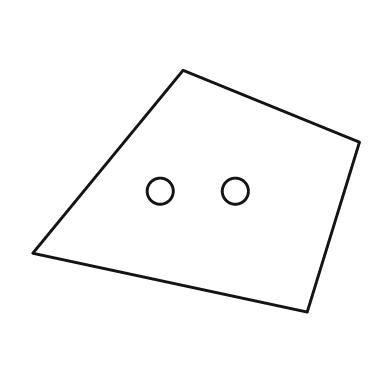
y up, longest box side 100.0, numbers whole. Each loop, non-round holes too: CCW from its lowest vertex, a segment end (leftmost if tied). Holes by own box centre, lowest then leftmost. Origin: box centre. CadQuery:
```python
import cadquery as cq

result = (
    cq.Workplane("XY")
    .moveTo(34.0, -37.0)
    .lineTo(50.0, 15.0)
    .lineTo(-4.0, 37.0)
    .lineTo(-50.0, -19.0)
    .close()
    .moveTo(-11.0, 0.0)
    .circle(4.0)
    .moveTo(12.0, 0.0)
    .circle(4.0)
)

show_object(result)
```